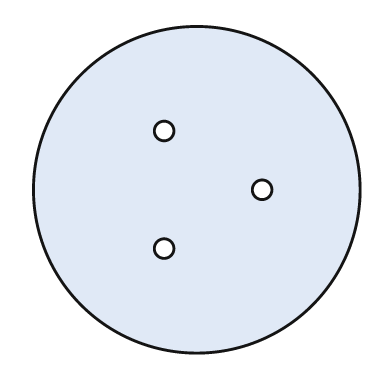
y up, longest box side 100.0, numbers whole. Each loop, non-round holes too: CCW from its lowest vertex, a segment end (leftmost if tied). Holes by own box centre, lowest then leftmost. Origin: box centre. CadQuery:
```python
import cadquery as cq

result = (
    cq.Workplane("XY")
    .moveTo(0.0, 0.0)
    .circle(50.0)
    .moveTo(-10.0, -18.0)
    .circle(3.0)
    .moveTo(20.0, 0.0)
    .circle(3.0)
    .moveTo(-10.0, 18.0)
    .circle(3.0)
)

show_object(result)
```